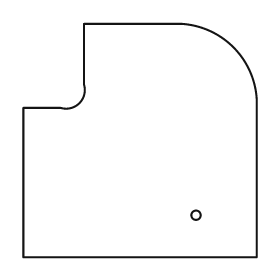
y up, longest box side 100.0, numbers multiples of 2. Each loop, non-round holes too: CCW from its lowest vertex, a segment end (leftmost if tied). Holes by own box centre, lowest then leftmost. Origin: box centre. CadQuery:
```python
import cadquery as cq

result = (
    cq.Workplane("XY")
    .moveTo(-50.0, -50.0)
    .lineTo(50.0, -50.0)
    .lineTo(50.0, 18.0)
    .threePointArc((40.0, 40.0), (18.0, 50.0))
    .lineTo(-24.0, 50.0)
    .lineTo(-24.0, 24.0)
    .threePointArc((-26.0, 16.0), (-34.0, 14.0))
    .lineTo(-50.0, 14.0)
    .close()
    .moveTo(24.0, -32.0)
    .circle(2.0)
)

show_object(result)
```